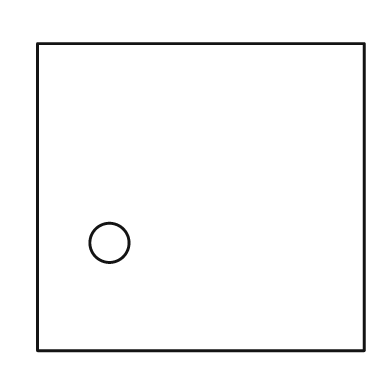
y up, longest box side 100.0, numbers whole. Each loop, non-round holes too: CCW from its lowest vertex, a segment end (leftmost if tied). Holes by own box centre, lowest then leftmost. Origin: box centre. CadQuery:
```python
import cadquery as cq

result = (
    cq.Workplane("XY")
    .moveTo(-50.0, -47.0)
    .lineTo(50.0, -47.0)
    .lineTo(50.0, 47.0)
    .lineTo(-50.0, 47.0)
    .close()
    .moveTo(-28.0, -14.0)
    .circle(6.0)
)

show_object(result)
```